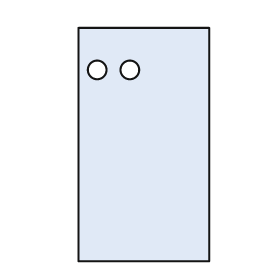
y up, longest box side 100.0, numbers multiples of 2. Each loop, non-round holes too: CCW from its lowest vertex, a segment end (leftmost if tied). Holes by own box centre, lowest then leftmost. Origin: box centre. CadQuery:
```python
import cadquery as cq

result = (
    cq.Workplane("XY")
    .moveTo(-28.0, -50.0)
    .lineTo(28.0, -50.0)
    .lineTo(28.0, 50.0)
    .lineTo(-28.0, 50.0)
    .close()
    .moveTo(-20.0, 32.0)
    .circle(4.0)
    .moveTo(-6.0, 32.0)
    .circle(4.0)
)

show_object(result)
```